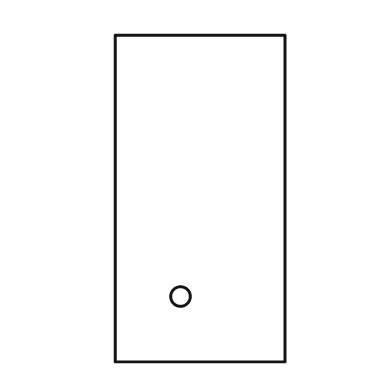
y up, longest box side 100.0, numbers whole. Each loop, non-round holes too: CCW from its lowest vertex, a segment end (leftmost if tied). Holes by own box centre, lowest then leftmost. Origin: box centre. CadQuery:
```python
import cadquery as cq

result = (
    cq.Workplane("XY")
    .moveTo(-26.0, -50.0)
    .lineTo(26.0, -50.0)
    .lineTo(26.0, 50.0)
    .lineTo(-26.0, 50.0)
    .close()
    .moveTo(-6.0, -30.0)
    .circle(3.0)
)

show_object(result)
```